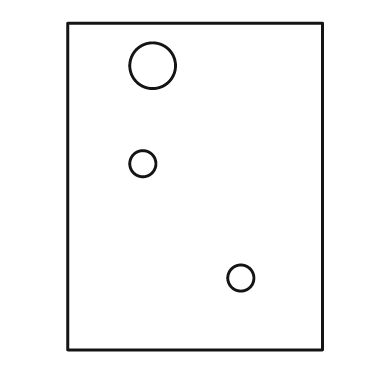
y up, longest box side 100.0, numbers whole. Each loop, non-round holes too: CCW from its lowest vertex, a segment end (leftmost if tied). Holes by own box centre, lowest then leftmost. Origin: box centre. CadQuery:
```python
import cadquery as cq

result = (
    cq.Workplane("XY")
    .moveTo(-39.0, -50.0)
    .lineTo(39.0, -50.0)
    .lineTo(39.0, 50.0)
    .lineTo(-39.0, 50.0)
    .close()
    .moveTo(14.0, -28.0)
    .circle(4.0)
    .moveTo(-16.0, 7.0)
    .circle(4.0)
    .moveTo(-13.0, 37.0)
    .circle(7.0)
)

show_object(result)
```